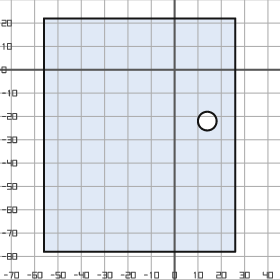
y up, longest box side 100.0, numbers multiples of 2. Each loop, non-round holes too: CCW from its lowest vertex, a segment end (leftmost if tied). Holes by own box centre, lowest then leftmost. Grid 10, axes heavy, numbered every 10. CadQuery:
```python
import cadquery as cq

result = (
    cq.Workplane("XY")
    .moveTo(-56.0, -78.0)
    .lineTo(26.0, -78.0)
    .lineTo(26.0, 22.0)
    .lineTo(-56.0, 22.0)
    .close()
    .moveTo(14.0, -22.0)
    .circle(4.0)
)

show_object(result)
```